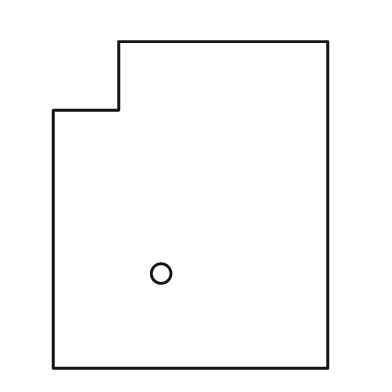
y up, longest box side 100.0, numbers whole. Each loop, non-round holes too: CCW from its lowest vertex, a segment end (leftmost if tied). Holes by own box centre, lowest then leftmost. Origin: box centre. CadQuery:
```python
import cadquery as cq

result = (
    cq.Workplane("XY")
    .moveTo(-42.0, -50.0)
    .lineTo(42.0, -50.0)
    .lineTo(42.0, 50.0)
    .lineTo(-22.0, 50.0)
    .lineTo(-22.0, 29.0)
    .lineTo(-42.0, 29.0)
    .close()
    .moveTo(-9.0, -21.0)
    .circle(3.0)
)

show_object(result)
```